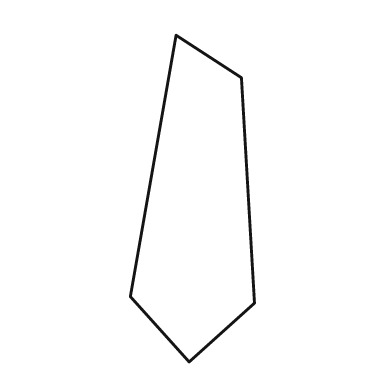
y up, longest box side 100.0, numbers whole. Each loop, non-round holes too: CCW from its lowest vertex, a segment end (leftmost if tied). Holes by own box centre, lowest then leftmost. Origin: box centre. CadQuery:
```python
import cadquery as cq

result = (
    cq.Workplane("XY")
    .moveTo(-1.0, -50.0)
    .lineTo(19.0, -32.0)
    .lineTo(15.0, 37.0)
    .lineTo(-5.0, 50.0)
    .lineTo(-19.0, -30.0)
    .close()
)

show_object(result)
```